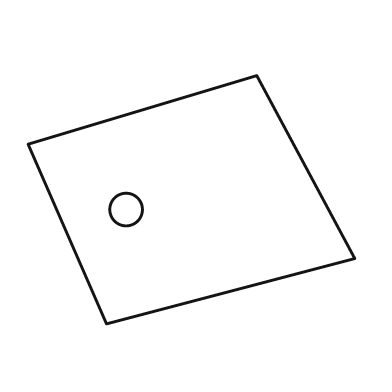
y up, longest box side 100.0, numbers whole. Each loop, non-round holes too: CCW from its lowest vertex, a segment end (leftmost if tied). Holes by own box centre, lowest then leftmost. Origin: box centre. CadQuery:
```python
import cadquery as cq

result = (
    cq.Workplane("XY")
    .moveTo(-26.0, -38.0)
    .lineTo(50.0, -18.0)
    .lineTo(20.0, 38.0)
    .lineTo(-50.0, 17.0)
    .close()
    .moveTo(-20.0, -3.0)
    .circle(5.0)
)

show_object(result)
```